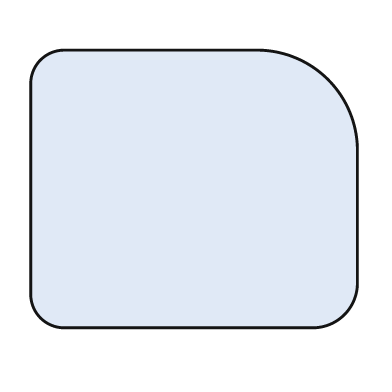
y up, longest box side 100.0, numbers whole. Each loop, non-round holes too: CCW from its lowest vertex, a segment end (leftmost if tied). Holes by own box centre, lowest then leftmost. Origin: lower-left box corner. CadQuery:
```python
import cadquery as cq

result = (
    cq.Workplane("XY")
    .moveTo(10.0, 0.0)
    .lineTo(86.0, 0.0)
    .threePointArc((96.0, 4.0), (100.0, 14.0))
    .lineTo(100.0, 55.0)
    .threePointArc((91.0, 76.0), (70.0, 85.0))
    .lineTo(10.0, 85.0)
    .threePointArc((3.0, 82.0), (0.0, 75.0))
    .lineTo(0.0, 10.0)
    .threePointArc((3.0, 3.0), (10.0, 0.0))
    .close()
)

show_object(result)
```